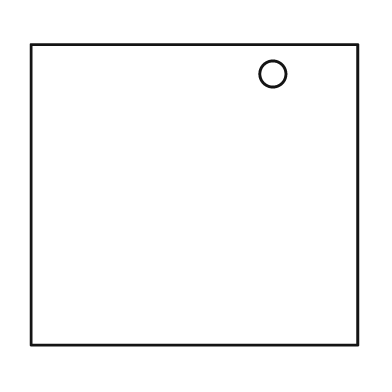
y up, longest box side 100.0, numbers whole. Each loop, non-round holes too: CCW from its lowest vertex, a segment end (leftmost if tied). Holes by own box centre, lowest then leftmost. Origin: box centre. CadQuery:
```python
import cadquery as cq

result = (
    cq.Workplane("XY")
    .moveTo(-50.0, -46.0)
    .lineTo(50.0, -46.0)
    .lineTo(50.0, 46.0)
    .lineTo(-50.0, 46.0)
    .close()
    .moveTo(24.0, 37.0)
    .circle(4.0)
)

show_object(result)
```